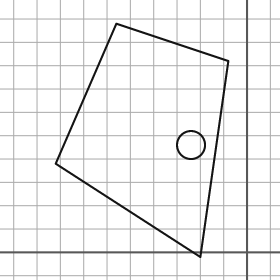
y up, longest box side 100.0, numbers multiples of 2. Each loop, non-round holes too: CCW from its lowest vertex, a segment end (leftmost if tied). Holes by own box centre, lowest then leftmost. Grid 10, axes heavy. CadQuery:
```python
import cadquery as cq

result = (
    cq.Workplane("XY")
    .moveTo(-20.0, -2.0)
    .lineTo(-8.0, 82.0)
    .lineTo(-56.0, 98.0)
    .lineTo(-82.0, 38.0)
    .close()
    .moveTo(-24.0, 46.0)
    .circle(6.0)
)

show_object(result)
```